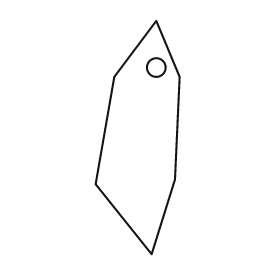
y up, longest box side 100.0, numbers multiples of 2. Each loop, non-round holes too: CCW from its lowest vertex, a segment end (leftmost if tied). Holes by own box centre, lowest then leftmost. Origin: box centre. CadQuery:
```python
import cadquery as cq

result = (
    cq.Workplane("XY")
    .moveTo(6.0, -50.0)
    .lineTo(16.0, -18.0)
    .lineTo(18.0, 26.0)
    .lineTo(8.0, 50.0)
    .lineTo(-10.0, 26.0)
    .lineTo(-18.0, -20.0)
    .close()
    .moveTo(8.0, 30.0)
    .circle(4.0)
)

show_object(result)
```